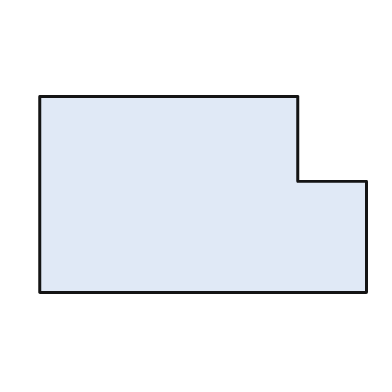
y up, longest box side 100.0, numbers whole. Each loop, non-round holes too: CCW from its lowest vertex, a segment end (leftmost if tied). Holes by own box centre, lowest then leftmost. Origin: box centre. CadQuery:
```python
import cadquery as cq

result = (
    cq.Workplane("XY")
    .moveTo(-50.0, -30.0)
    .lineTo(50.0, -30.0)
    .lineTo(50.0, 4.0)
    .lineTo(29.0, 4.0)
    .lineTo(29.0, 30.0)
    .lineTo(-50.0, 30.0)
    .close()
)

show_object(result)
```